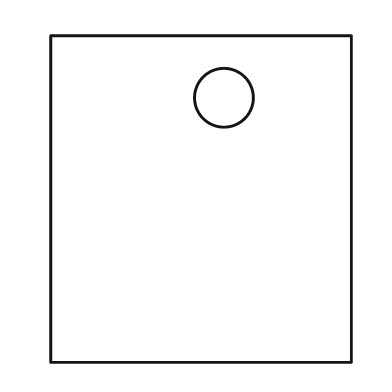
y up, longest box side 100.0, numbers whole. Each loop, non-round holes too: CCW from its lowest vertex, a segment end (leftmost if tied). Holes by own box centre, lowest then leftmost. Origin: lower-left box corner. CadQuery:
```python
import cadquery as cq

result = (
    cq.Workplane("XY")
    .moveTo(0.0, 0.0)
    .lineTo(92.0, 0.0)
    .lineTo(92.0, 100.0)
    .lineTo(0.0, 100.0)
    .close()
    .moveTo(53.0, 81.0)
    .circle(9.0)
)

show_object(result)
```